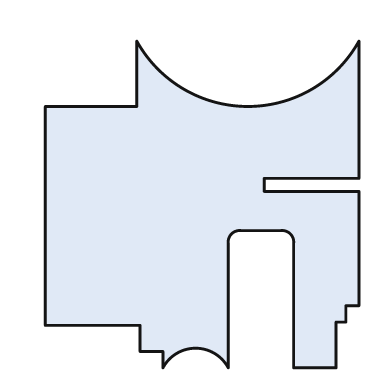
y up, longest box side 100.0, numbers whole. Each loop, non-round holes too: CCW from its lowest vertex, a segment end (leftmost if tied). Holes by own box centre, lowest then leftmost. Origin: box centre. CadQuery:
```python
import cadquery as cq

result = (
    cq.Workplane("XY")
    .moveTo(-12.0, -50.0)
    .threePointArc((-2.0, -44.0), (8.0, -50.0))
    .lineTo(8.0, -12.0)
    .threePointArc((9.0, -9.0), (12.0, -8.0))
    .lineTo(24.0, -8.0)
    .threePointArc((27.0, -9.0), (28.0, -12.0))
    .lineTo(28.0, -50.0)
    .lineTo(41.0, -50.0)
    .lineTo(41.0, -36.0)
    .lineTo(44.0, -36.0)
    .lineTo(44.0, -31.0)
    .lineTo(48.0, -31.0)
    .lineTo(48.0, 4.0)
    .lineTo(19.0, 4.0)
    .lineTo(19.0, 8.0)
    .lineTo(48.0, 8.0)
    .lineTo(48.0, 50.0)
    .threePointArc((14.0, 30.0), (-20.0, 50.0))
    .lineTo(-20.0, 30.0)
    .lineTo(-48.0, 30.0)
    .lineTo(-48.0, -37.0)
    .lineTo(-19.0, -37.0)
    .lineTo(-19.0, -45.0)
    .lineTo(-12.0, -45.0)
    .close()
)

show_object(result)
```